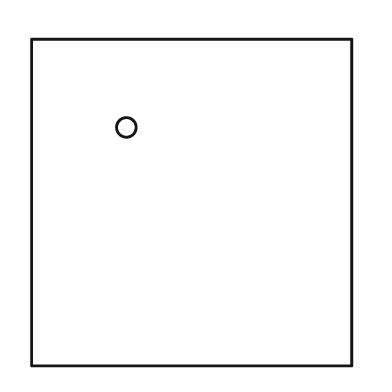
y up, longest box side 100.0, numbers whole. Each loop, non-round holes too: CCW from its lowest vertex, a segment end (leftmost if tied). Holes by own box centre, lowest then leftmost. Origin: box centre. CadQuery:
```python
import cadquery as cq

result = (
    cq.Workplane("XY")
    .moveTo(-49.0, -50.0)
    .lineTo(49.0, -50.0)
    .lineTo(49.0, 50.0)
    .lineTo(-49.0, 50.0)
    .close()
    .moveTo(-20.0, 23.0)
    .circle(3.0)
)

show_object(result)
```